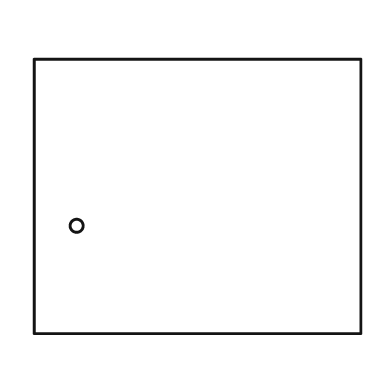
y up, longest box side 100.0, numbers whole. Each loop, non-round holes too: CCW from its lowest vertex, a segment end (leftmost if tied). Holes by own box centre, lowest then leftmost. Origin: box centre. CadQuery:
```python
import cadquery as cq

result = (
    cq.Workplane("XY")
    .moveTo(-50.0, -42.0)
    .lineTo(50.0, -42.0)
    .lineTo(50.0, 42.0)
    .lineTo(-50.0, 42.0)
    .close()
    .moveTo(-37.0, -9.0)
    .circle(2.0)
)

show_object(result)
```